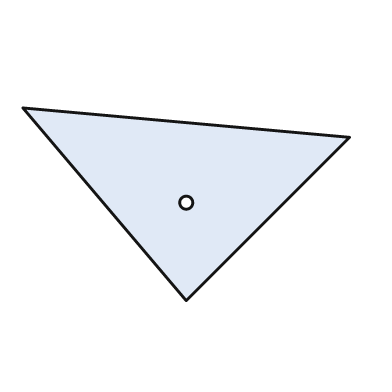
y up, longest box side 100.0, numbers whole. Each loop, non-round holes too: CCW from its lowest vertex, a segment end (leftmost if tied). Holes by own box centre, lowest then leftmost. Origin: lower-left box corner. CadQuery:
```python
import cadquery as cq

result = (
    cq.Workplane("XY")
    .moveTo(50.0, 0.0)
    .lineTo(100.0, 50.0)
    .lineTo(0.0, 59.0)
    .close()
    .moveTo(50.0, 30.0)
    .circle(2.0)
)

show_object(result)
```